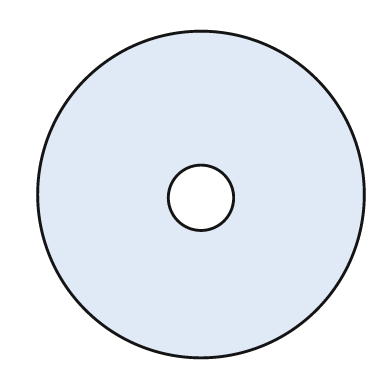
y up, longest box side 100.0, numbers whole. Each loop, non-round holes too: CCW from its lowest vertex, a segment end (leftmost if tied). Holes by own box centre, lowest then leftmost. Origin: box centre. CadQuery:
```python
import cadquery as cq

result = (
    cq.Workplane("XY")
    .moveTo(0.0, 0.0)
    .circle(50.0)
    .moveTo(0.0, -1.0)
    .circle(10.0)
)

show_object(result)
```